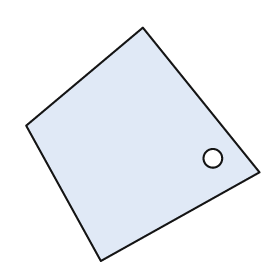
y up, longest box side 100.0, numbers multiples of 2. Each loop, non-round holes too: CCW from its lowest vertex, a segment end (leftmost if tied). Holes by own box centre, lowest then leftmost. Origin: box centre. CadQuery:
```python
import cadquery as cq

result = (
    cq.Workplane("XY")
    .moveTo(-18.0, -50.0)
    .lineTo(50.0, -12.0)
    .lineTo(0.0, 50.0)
    .lineTo(-50.0, 8.0)
    .close()
    .moveTo(30.0, -6.0)
    .circle(4.0)
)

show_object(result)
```